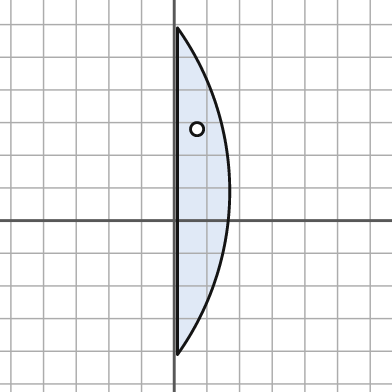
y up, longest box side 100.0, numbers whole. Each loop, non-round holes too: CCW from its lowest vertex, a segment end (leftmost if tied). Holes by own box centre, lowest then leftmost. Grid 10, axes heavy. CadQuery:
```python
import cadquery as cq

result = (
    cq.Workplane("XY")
    .moveTo(1.0, -41.0)
    .threePointArc((17.0, 9.0), (1.0, 59.0))
    .close()
    .moveTo(7.0, 28.0)
    .circle(2.0)
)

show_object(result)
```